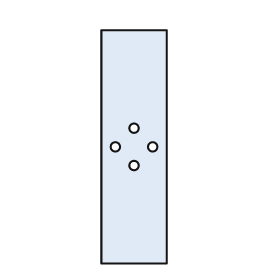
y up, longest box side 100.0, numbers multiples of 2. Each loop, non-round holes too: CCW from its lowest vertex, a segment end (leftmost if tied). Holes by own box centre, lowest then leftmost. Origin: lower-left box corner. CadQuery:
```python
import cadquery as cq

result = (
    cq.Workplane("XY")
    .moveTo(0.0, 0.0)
    .lineTo(28.0, 0.0)
    .lineTo(28.0, 100.0)
    .lineTo(0.0, 100.0)
    .close()
    .moveTo(14.0, 42.0)
    .circle(2.0)
    .moveTo(6.0, 50.0)
    .circle(2.0)
    .moveTo(22.0, 50.0)
    .circle(2.0)
    .moveTo(14.0, 58.0)
    .circle(2.0)
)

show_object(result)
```